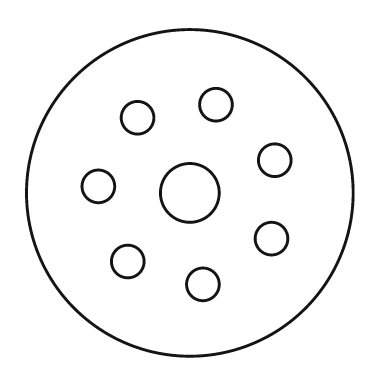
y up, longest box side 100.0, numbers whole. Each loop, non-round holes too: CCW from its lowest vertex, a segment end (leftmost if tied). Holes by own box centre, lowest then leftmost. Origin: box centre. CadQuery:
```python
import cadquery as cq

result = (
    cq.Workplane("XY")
    .moveTo(0.0, 0.0)
    .circle(50.0)
    .moveTo(4.0, -28.0)
    .circle(5.0)
    .moveTo(-19.0, -21.0)
    .circle(5.0)
    .moveTo(25.0, -14.0)
    .circle(5.0)
    .moveTo(0.0, 0.0)
    .circle(9.0)
    .moveTo(-28.0, 2.0)
    .circle(5.0)
    .moveTo(26.0, 10.0)
    .circle(5.0)
    .moveTo(-16.0, 23.0)
    .circle(5.0)
    .moveTo(8.0, 27.0)
    .circle(5.0)
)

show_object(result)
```